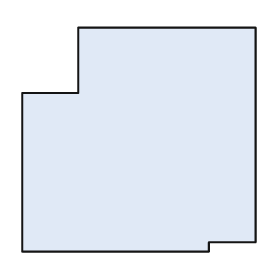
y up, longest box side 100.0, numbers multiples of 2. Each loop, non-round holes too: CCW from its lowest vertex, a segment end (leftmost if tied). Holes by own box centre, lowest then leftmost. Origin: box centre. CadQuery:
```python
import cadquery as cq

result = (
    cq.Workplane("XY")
    .moveTo(-50.0, -48.0)
    .lineTo(30.0, -48.0)
    .lineTo(30.0, -44.0)
    .lineTo(50.0, -44.0)
    .lineTo(50.0, 48.0)
    .lineTo(-26.0, 48.0)
    .lineTo(-26.0, 20.0)
    .lineTo(-50.0, 20.0)
    .close()
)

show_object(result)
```